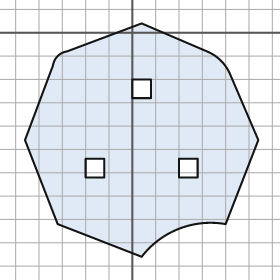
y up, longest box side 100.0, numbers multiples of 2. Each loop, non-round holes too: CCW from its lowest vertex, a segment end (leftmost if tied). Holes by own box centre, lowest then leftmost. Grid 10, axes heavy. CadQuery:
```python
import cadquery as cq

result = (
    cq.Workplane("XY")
    .moveTo(4.0, -96.0)
    .threePointArc((20.0, -84.0), (40.0, -82.0))
    .lineTo(54.0, -46.0)
    .lineTo(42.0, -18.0)
    .threePointArc((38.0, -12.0), (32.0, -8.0))
    .lineTo(4.0, 4.0)
    .lineTo(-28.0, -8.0)
    .threePointArc((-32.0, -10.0), (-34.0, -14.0))
    .lineTo(-46.0, -46.0)
    .lineTo(-32.0, -82.0)
    .close()
    .moveTo(-20.0, -62.0)
    .lineTo(-12.0, -62.0)
    .lineTo(-12.0, -54.0)
    .lineTo(-20.0, -54.0)
    .close()
    .moveTo(20.0, -62.0)
    .lineTo(28.0, -62.0)
    .lineTo(28.0, -54.0)
    .lineTo(20.0, -54.0)
    .close()
    .moveTo(0.0, -28.0)
    .lineTo(8.0, -28.0)
    .lineTo(8.0, -20.0)
    .lineTo(0.0, -20.0)
    .close()
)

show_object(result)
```